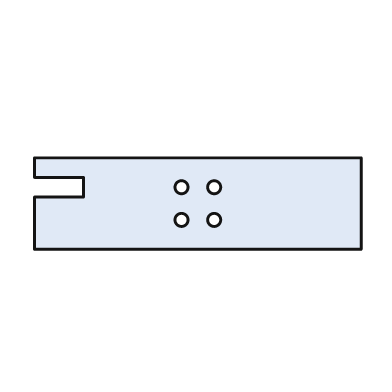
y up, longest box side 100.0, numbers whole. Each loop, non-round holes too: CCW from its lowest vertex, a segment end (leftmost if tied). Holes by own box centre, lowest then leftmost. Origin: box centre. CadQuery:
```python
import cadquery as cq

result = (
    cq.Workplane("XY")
    .moveTo(-50.0, -14.0)
    .lineTo(50.0, -14.0)
    .lineTo(50.0, 14.0)
    .lineTo(-50.0, 14.0)
    .lineTo(-50.0, 8.0)
    .lineTo(-35.0, 8.0)
    .lineTo(-35.0, 2.0)
    .lineTo(-50.0, 2.0)
    .close()
    .moveTo(-5.0, -5.0)
    .circle(2.0)
    .moveTo(5.0, -5.0)
    .circle(2.0)
    .moveTo(-5.0, 5.0)
    .circle(2.0)
    .moveTo(5.0, 5.0)
    .circle(2.0)
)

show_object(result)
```